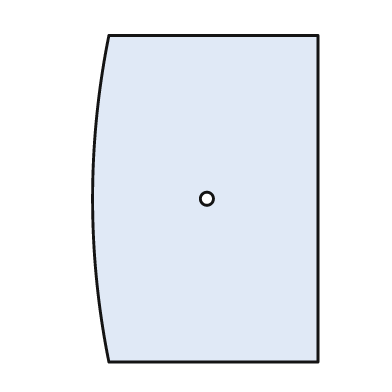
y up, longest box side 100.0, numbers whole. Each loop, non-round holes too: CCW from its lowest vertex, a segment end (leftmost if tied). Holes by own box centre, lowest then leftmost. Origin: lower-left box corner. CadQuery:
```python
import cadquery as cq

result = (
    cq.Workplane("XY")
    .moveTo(5.0, 0.0)
    .lineTo(69.0, 0.0)
    .lineTo(69.0, 100.0)
    .lineTo(5.0, 100.0)
    .threePointArc((0.0, 50.0), (5.0, 0.0))
    .close()
    .moveTo(35.0, 50.0)
    .circle(2.0)
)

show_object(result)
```